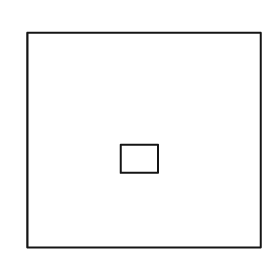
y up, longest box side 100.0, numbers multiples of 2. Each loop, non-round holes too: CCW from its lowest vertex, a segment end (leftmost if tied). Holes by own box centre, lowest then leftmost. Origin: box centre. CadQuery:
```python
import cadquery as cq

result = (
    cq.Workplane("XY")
    .moveTo(-50.0, -46.0)
    .lineTo(50.0, -46.0)
    .lineTo(50.0, 46.0)
    .lineTo(-50.0, 46.0)
    .close()
    .moveTo(-10.0, -14.0)
    .lineTo(6.0, -14.0)
    .lineTo(6.0, -2.0)
    .lineTo(-10.0, -2.0)
    .close()
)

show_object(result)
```